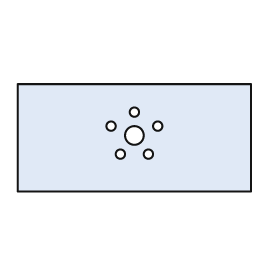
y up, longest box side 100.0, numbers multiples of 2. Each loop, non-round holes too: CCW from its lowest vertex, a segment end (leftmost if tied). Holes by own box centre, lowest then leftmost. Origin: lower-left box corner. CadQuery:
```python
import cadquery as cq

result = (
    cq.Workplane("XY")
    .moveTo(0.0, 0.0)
    .lineTo(100.0, 0.0)
    .lineTo(100.0, 46.0)
    .lineTo(0.0, 46.0)
    .close()
    .moveTo(44.0, 16.0)
    .circle(2.0)
    .moveTo(56.0, 16.0)
    .circle(2.0)
    .moveTo(50.0, 24.0)
    .circle(4.0)
    .moveTo(40.0, 28.0)
    .circle(2.0)
    .moveTo(60.0, 28.0)
    .circle(2.0)
    .moveTo(50.0, 34.0)
    .circle(2.0)
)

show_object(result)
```